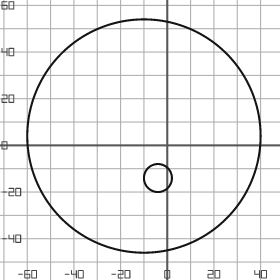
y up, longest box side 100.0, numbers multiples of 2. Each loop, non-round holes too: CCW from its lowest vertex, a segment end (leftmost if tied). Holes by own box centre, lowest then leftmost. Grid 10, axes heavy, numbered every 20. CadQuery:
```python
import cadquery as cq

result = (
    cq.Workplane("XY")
    .moveTo(-10.0, 4.0)
    .circle(50.0)
    .moveTo(-4.0, -14.0)
    .circle(6.0)
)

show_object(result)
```